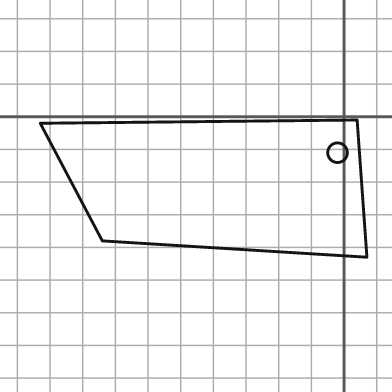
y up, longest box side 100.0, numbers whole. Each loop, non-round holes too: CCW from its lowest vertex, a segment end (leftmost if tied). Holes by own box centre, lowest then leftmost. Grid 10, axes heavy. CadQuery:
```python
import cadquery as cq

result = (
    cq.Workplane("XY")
    .moveTo(7.0, -43.0)
    .lineTo(4.0, -1.0)
    .lineTo(-93.0, -2.0)
    .lineTo(-74.0, -38.0)
    .close()
    .moveTo(-2.0, -11.0)
    .circle(3.0)
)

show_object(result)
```